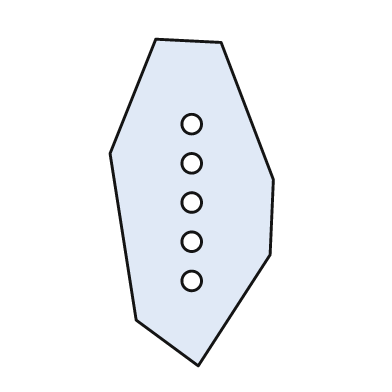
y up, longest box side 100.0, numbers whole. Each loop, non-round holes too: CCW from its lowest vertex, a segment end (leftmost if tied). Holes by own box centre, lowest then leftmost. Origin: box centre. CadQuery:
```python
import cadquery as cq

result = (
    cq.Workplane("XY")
    .moveTo(2.0, -50.0)
    .lineTo(24.0, -16.0)
    .lineTo(25.0, 7.0)
    .lineTo(9.0, 49.0)
    .lineTo(-11.0, 50.0)
    .lineTo(-25.0, 15.0)
    .lineTo(-17.0, -36.0)
    .close()
    .moveTo(0.0, -24.0)
    .circle(3.0)
    .moveTo(0.0, -12.0)
    .circle(3.0)
    .moveTo(0.0, 0.0)
    .circle(3.0)
    .moveTo(0.0, 12.0)
    .circle(3.0)
    .moveTo(0.0, 24.0)
    .circle(3.0)
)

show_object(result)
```